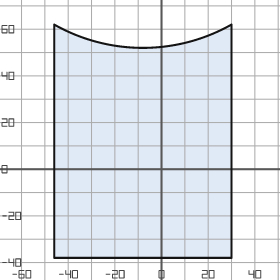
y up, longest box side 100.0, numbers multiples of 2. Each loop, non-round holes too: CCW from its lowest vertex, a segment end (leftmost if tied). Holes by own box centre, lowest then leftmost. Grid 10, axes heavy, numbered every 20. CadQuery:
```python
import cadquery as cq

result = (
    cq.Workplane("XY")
    .moveTo(-46.0, -38.0)
    .lineTo(30.0, -38.0)
    .lineTo(30.0, 62.0)
    .threePointArc((-8.0, 52.0), (-46.0, 62.0))
    .close()
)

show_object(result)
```